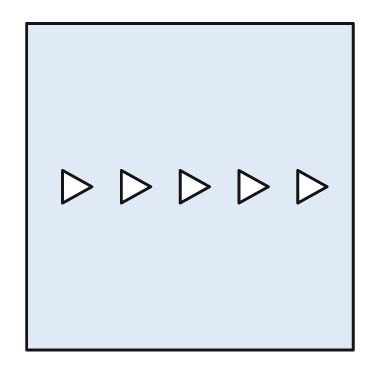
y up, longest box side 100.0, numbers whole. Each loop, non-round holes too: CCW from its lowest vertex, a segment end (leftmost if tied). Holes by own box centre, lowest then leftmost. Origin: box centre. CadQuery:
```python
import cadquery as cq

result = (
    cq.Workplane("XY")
    .moveTo(-50.0, -50.0)
    .lineTo(50.0, -50.0)
    .lineTo(50.0, 50.0)
    .lineTo(-50.0, 50.0)
    .close()
    .moveTo(-39.0, -5.0)
    .lineTo(-30.0, 0.0)
    .lineTo(-39.0, 5.0)
    .close()
    .moveTo(-21.0, -5.0)
    .lineTo(-12.0, 0.0)
    .lineTo(-21.0, 5.0)
    .close()
    .moveTo(-3.0, -5.0)
    .lineTo(6.0, 0.0)
    .lineTo(-3.0, 5.0)
    .close()
    .moveTo(15.0, -5.0)
    .lineTo(24.0, 0.0)
    .lineTo(15.0, 5.0)
    .close()
    .moveTo(33.0, -5.0)
    .lineTo(42.0, 0.0)
    .lineTo(33.0, 5.0)
    .close()
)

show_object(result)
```